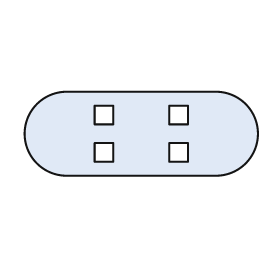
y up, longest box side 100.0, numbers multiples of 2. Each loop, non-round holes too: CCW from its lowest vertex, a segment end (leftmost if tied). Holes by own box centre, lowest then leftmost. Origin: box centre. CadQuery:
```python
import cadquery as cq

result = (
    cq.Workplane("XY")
    .moveTo(-32.0, -18.0)
    .lineTo(32.0, -18.0)
    .threePointArc((50.0, 0.0), (32.0, 18.0))
    .lineTo(-32.0, 18.0)
    .threePointArc((-50.0, 0.0), (-32.0, -18.0))
    .close()
    .moveTo(-20.0, -12.0)
    .lineTo(-12.0, -12.0)
    .lineTo(-12.0, -4.0)
    .lineTo(-20.0, -4.0)
    .close()
    .moveTo(12.0, -12.0)
    .lineTo(20.0, -12.0)
    .lineTo(20.0, -4.0)
    .lineTo(12.0, -4.0)
    .close()
    .moveTo(-20.0, 4.0)
    .lineTo(-12.0, 4.0)
    .lineTo(-12.0, 12.0)
    .lineTo(-20.0, 12.0)
    .close()
    .moveTo(12.0, 4.0)
    .lineTo(20.0, 4.0)
    .lineTo(20.0, 12.0)
    .lineTo(12.0, 12.0)
    .close()
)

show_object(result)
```